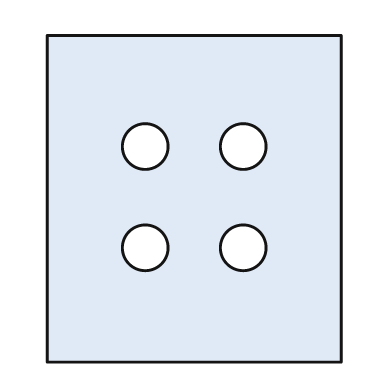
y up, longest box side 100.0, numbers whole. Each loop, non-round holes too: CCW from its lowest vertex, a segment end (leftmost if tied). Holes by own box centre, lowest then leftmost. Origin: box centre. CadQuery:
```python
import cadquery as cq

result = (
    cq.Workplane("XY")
    .moveTo(-45.0, -50.0)
    .lineTo(45.0, -50.0)
    .lineTo(45.0, 50.0)
    .lineTo(-45.0, 50.0)
    .close()
    .moveTo(-15.0, -15.0)
    .circle(7.0)
    .moveTo(15.0, -15.0)
    .circle(7.0)
    .moveTo(-15.0, 16.0)
    .circle(7.0)
    .moveTo(15.0, 16.0)
    .circle(7.0)
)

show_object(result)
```